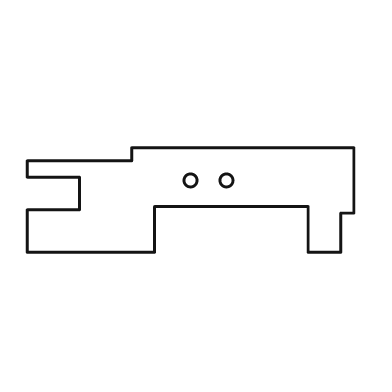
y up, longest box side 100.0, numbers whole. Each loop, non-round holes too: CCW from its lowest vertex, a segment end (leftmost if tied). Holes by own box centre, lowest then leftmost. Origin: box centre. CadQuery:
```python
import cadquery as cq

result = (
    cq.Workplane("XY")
    .moveTo(-50.0, -16.0)
    .lineTo(-11.0, -16.0)
    .lineTo(-11.0, -2.0)
    .lineTo(36.0, -2.0)
    .lineTo(36.0, -16.0)
    .lineTo(46.0, -16.0)
    .lineTo(46.0, -4.0)
    .lineTo(50.0, -4.0)
    .lineTo(50.0, 16.0)
    .lineTo(-18.0, 16.0)
    .lineTo(-18.0, 12.0)
    .lineTo(-50.0, 12.0)
    .lineTo(-50.0, 7.0)
    .lineTo(-34.0, 7.0)
    .lineTo(-34.0, -3.0)
    .lineTo(-50.0, -3.0)
    .close()
    .moveTo(0.0, 6.0)
    .circle(2.0)
    .moveTo(11.0, 6.0)
    .circle(2.0)
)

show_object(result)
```